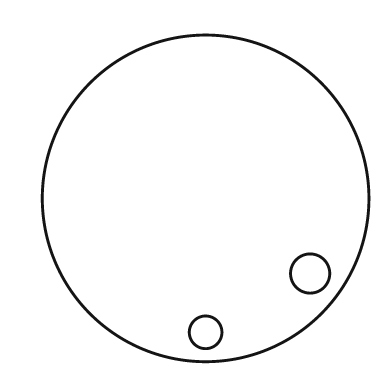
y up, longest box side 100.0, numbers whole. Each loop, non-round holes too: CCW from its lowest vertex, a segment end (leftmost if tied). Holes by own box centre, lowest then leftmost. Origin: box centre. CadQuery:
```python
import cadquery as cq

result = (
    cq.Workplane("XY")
    .moveTo(0.0, 0.0)
    .circle(50.0)
    .moveTo(0.0, -41.0)
    .circle(5.0)
    .moveTo(32.0, -23.0)
    .circle(6.0)
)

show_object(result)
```